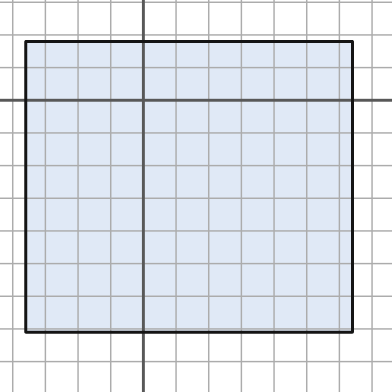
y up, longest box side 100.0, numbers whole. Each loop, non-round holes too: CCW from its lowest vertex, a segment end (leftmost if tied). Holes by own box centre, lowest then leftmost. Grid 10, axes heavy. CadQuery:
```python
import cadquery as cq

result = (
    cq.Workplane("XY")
    .moveTo(-36.0, -71.0)
    .lineTo(64.0, -71.0)
    .lineTo(64.0, 18.0)
    .lineTo(-36.0, 18.0)
    .close()
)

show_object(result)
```